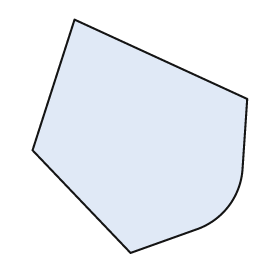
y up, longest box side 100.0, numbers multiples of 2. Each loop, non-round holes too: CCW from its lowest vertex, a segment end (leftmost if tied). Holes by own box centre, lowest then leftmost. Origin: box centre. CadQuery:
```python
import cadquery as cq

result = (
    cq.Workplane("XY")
    .moveTo(-4.0, -50.0)
    .lineTo(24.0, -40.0)
    .threePointArc((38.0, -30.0), (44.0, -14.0))
    .lineTo(46.0, 16.0)
    .lineTo(-28.0, 50.0)
    .lineTo(-46.0, -6.0)
    .close()
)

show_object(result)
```